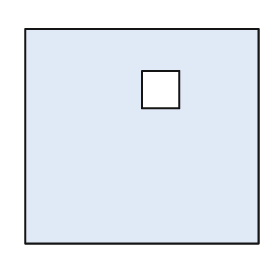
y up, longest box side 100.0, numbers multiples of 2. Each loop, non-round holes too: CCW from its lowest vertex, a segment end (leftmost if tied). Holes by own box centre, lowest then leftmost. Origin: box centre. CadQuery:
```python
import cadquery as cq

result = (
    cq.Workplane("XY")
    .moveTo(-50.0, -46.0)
    .lineTo(50.0, -46.0)
    .lineTo(50.0, 46.0)
    .lineTo(-50.0, 46.0)
    .close()
    .moveTo(0.0, 12.0)
    .lineTo(16.0, 12.0)
    .lineTo(16.0, 28.0)
    .lineTo(0.0, 28.0)
    .close()
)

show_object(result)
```